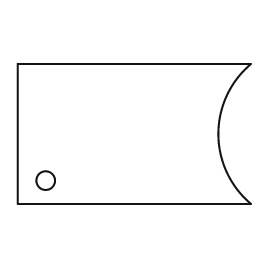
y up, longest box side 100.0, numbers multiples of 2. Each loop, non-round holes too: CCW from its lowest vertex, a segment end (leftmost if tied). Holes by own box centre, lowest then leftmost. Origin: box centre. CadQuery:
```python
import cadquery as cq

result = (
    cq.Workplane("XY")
    .moveTo(-50.0, -30.0)
    .lineTo(50.0, -30.0)
    .threePointArc((36.0, 0.0), (50.0, 30.0))
    .lineTo(-50.0, 30.0)
    .close()
    .moveTo(-38.0, -20.0)
    .circle(4.0)
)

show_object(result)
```